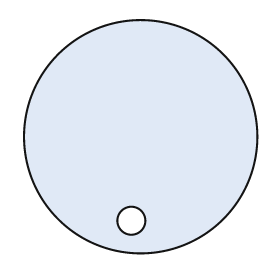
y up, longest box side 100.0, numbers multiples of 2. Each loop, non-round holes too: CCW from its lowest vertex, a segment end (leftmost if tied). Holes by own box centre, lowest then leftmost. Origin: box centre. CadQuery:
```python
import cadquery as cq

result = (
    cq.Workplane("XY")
    .moveTo(0.0, 0.0)
    .circle(50.0)
    .moveTo(-4.0, -36.0)
    .circle(6.0)
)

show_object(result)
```